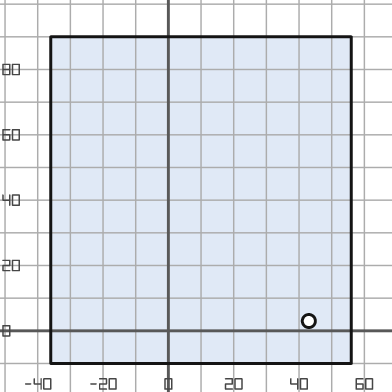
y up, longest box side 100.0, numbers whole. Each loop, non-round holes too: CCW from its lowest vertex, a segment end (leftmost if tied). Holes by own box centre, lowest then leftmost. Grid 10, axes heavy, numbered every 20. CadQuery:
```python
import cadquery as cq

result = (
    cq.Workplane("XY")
    .moveTo(-36.0, -10.0)
    .lineTo(56.0, -10.0)
    .lineTo(56.0, 90.0)
    .lineTo(-36.0, 90.0)
    .close()
    .moveTo(43.0, 3.0)
    .circle(2.0)
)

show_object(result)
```